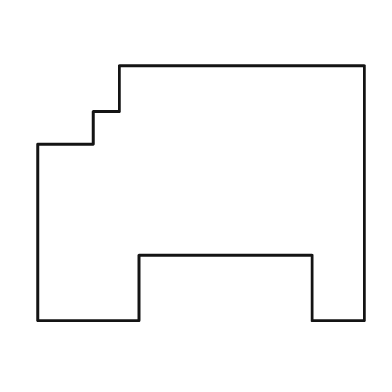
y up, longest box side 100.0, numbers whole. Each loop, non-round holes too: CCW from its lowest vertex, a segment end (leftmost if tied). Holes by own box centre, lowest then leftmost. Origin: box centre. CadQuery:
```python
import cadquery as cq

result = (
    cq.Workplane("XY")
    .moveTo(-50.0, -39.0)
    .lineTo(-19.0, -39.0)
    .lineTo(-19.0, -19.0)
    .lineTo(34.0, -19.0)
    .lineTo(34.0, -39.0)
    .lineTo(50.0, -39.0)
    .lineTo(50.0, 39.0)
    .lineTo(-25.0, 39.0)
    .lineTo(-25.0, 25.0)
    .lineTo(-33.0, 25.0)
    .lineTo(-33.0, 15.0)
    .lineTo(-50.0, 15.0)
    .close()
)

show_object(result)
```